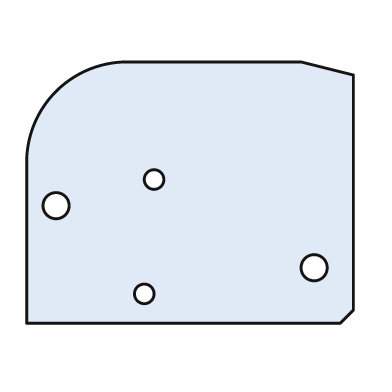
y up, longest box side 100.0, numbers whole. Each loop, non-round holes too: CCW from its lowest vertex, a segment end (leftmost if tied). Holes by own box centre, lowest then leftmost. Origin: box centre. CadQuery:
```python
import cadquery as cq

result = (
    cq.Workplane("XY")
    .moveTo(-50.0, -40.0)
    .lineTo(46.0, -40.0)
    .lineTo(50.0, -36.0)
    .lineTo(50.0, 36.0)
    .lineTo(34.0, 40.0)
    .lineTo(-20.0, 40.0)
    .threePointArc((-41.0, 31.0), (-50.0, 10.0))
    .close()
    .moveTo(-14.0, -31.0)
    .circle(3.0)
    .moveTo(38.0, -23.0)
    .circle(4.0)
    .moveTo(-41.0, -4.0)
    .circle(4.0)
    .moveTo(-11.0, 4.0)
    .circle(3.0)
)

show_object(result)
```